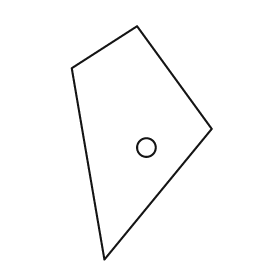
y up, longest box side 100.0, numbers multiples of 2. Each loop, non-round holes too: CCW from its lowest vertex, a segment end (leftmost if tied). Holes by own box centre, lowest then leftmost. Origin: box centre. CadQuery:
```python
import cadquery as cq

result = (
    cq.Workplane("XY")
    .moveTo(-16.0, -50.0)
    .lineTo(30.0, 6.0)
    .lineTo(-2.0, 50.0)
    .lineTo(-30.0, 32.0)
    .close()
    .moveTo(2.0, -2.0)
    .circle(4.0)
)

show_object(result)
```